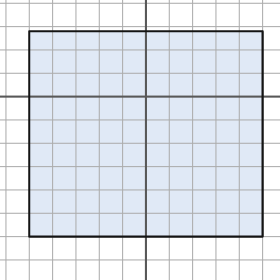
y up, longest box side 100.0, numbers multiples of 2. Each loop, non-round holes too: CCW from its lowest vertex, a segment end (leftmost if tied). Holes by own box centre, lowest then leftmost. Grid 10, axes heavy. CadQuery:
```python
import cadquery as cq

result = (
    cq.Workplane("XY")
    .moveTo(-50.0, -60.0)
    .lineTo(50.0, -60.0)
    .lineTo(50.0, 28.0)
    .lineTo(-50.0, 28.0)
    .close()
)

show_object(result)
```